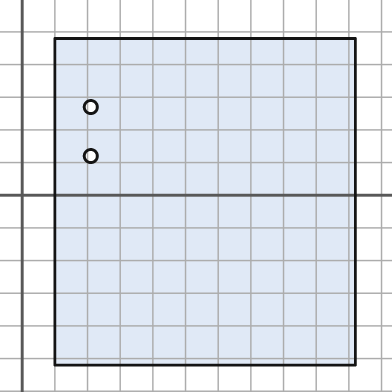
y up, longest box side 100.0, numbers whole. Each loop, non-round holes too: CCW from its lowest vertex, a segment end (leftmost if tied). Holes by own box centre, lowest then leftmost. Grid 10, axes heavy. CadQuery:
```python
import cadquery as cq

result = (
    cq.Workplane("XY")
    .moveTo(10.0, -52.0)
    .lineTo(102.0, -52.0)
    .lineTo(102.0, 48.0)
    .lineTo(10.0, 48.0)
    .close()
    .moveTo(21.0, 12.0)
    .circle(2.0)
    .moveTo(21.0, 27.0)
    .circle(2.0)
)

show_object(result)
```